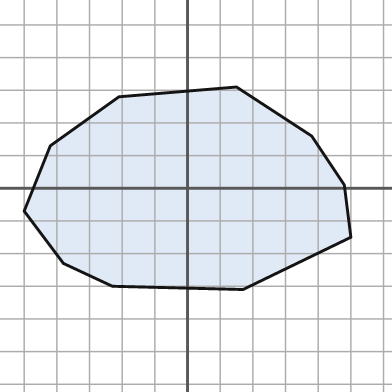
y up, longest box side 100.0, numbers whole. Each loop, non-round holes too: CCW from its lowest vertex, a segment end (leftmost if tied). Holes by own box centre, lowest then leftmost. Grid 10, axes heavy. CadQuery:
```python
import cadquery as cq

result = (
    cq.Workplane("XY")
    .moveTo(17.0, -31.0)
    .lineTo(50.0, -15.0)
    .lineTo(48.0, 1.0)
    .lineTo(38.0, 16.0)
    .lineTo(15.0, 31.0)
    .lineTo(-21.0, 28.0)
    .lineTo(-42.0, 13.0)
    .lineTo(-50.0, -7.0)
    .lineTo(-38.0, -23.0)
    .lineTo(-23.0, -30.0)
    .close()
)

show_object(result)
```